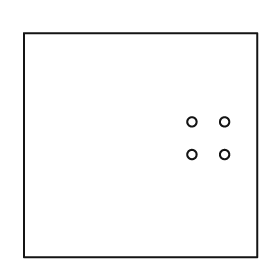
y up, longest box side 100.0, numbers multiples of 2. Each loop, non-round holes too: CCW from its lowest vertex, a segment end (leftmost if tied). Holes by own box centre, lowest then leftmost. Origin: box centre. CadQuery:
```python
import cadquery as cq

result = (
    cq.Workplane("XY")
    .moveTo(-50.0, -48.0)
    .lineTo(50.0, -48.0)
    .lineTo(50.0, 48.0)
    .lineTo(-50.0, 48.0)
    .close()
    .moveTo(22.0, -4.0)
    .circle(2.0)
    .moveTo(36.0, -4.0)
    .circle(2.0)
    .moveTo(22.0, 10.0)
    .circle(2.0)
    .moveTo(36.0, 10.0)
    .circle(2.0)
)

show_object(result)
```